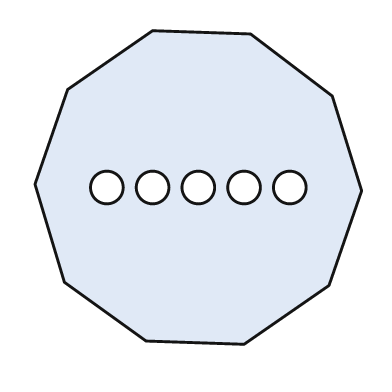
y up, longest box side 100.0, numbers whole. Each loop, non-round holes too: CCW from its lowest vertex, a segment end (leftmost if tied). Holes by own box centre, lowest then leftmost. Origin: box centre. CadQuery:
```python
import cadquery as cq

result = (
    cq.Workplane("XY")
    .moveTo(14.0, -48.0)
    .lineTo(40.0, -30.0)
    .lineTo(50.0, -1.0)
    .lineTo(41.0, 28.0)
    .lineTo(16.0, 47.0)
    .lineTo(-14.0, 48.0)
    .lineTo(-40.0, 30.0)
    .lineTo(-50.0, 1.0)
    .lineTo(-41.0, -29.0)
    .lineTo(-16.0, -47.0)
    .close()
    .moveTo(-28.0, 0.0)
    .circle(5.0)
    .moveTo(-14.0, 0.0)
    .circle(5.0)
    .moveTo(0.0, 0.0)
    .circle(5.0)
    .moveTo(14.0, 0.0)
    .circle(5.0)
    .moveTo(28.0, 0.0)
    .circle(5.0)
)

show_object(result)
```